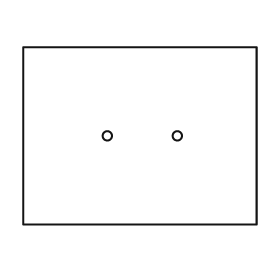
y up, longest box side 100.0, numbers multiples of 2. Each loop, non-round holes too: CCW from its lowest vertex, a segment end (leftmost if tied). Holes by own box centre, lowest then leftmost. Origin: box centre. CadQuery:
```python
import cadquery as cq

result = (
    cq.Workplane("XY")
    .moveTo(-50.0, -38.0)
    .lineTo(50.0, -38.0)
    .lineTo(50.0, 38.0)
    .lineTo(-50.0, 38.0)
    .close()
    .moveTo(-14.0, 0.0)
    .circle(2.0)
    .moveTo(16.0, 0.0)
    .circle(2.0)
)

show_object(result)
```